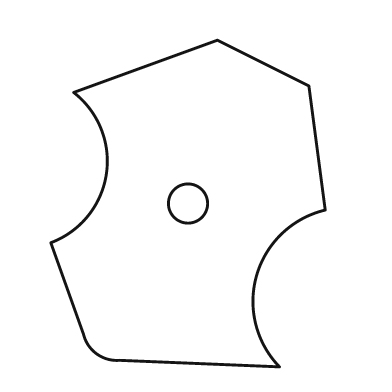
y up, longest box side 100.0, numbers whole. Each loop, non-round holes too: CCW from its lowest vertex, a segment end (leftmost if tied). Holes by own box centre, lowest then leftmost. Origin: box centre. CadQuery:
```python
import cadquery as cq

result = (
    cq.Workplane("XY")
    .moveTo(28.0, -50.0)
    .threePointArc((21.0, -22.0), (42.0, -2.0))
    .lineTo(37.0, 36.0)
    .lineTo(9.0, 50.0)
    .lineTo(-35.0, 34.0)
    .threePointArc((-25.0, 9.0), (-42.0, -12.0))
    .lineTo(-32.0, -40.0)
    .threePointArc((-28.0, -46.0), (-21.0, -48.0))
    .close()
    .moveTo(0.0, 0.0)
    .circle(6.0)
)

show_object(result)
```